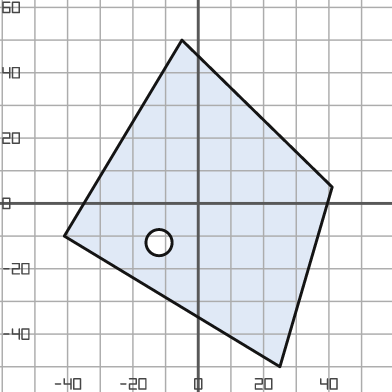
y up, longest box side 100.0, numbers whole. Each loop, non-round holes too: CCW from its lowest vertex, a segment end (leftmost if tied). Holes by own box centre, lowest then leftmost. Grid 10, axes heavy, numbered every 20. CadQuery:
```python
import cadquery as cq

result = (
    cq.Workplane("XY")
    .moveTo(25.0, -50.0)
    .lineTo(41.0, 5.0)
    .lineTo(-5.0, 50.0)
    .lineTo(-41.0, -10.0)
    .close()
    .moveTo(-12.0, -12.0)
    .circle(4.0)
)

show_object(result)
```